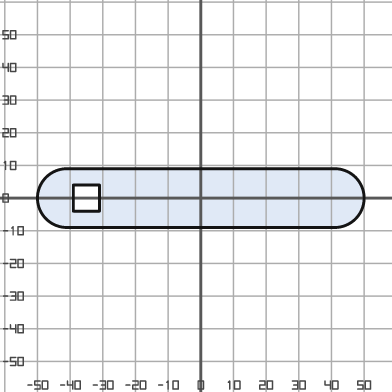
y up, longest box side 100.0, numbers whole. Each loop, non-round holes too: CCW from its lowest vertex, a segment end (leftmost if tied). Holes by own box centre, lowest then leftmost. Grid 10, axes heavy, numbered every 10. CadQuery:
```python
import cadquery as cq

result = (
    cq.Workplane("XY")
    .moveTo(-41.0, -9.0)
    .lineTo(41.0, -9.0)
    .threePointArc((50.0, 0.0), (41.0, 9.0))
    .lineTo(-41.0, 9.0)
    .threePointArc((-50.0, 0.0), (-41.0, -9.0))
    .close()
    .moveTo(-39.0, -4.0)
    .lineTo(-31.0, -4.0)
    .lineTo(-31.0, 4.0)
    .lineTo(-39.0, 4.0)
    .close()
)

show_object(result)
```